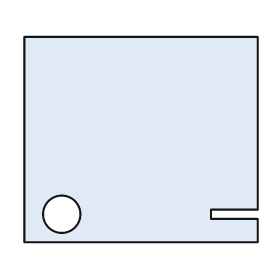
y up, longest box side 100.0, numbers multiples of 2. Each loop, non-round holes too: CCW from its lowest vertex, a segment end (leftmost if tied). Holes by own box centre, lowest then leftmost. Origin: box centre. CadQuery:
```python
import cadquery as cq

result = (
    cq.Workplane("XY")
    .moveTo(-50.0, -44.0)
    .lineTo(50.0, -44.0)
    .lineTo(50.0, -34.0)
    .lineTo(30.0, -34.0)
    .lineTo(30.0, -30.0)
    .lineTo(50.0, -30.0)
    .lineTo(50.0, 44.0)
    .lineTo(-50.0, 44.0)
    .close()
    .moveTo(-34.0, -32.0)
    .circle(8.0)
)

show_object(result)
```